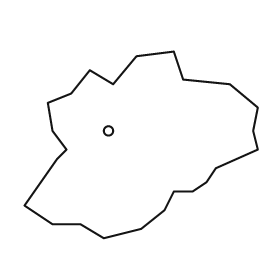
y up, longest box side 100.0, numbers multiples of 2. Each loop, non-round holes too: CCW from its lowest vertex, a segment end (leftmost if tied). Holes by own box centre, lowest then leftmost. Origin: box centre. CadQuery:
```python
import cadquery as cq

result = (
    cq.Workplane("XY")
    .moveTo(-16.0, -40.0)
    .lineTo(0.0, -36.0)
    .lineTo(10.0, -28.0)
    .lineTo(14.0, -20.0)
    .lineTo(22.0, -20.0)
    .lineTo(28.0, -16.0)
    .lineTo(32.0, -10.0)
    .lineTo(50.0, -2.0)
    .lineTo(48.0, 6.0)
    .lineTo(50.0, 16.0)
    .lineTo(38.0, 26.0)
    .lineTo(18.0, 28.0)
    .lineTo(14.0, 40.0)
    .lineTo(-2.0, 38.0)
    .lineTo(-12.0, 26.0)
    .lineTo(-22.0, 32.0)
    .lineTo(-30.0, 22.0)
    .lineTo(-40.0, 18.0)
    .lineTo(-38.0, 6.0)
    .lineTo(-32.0, -2.0)
    .lineTo(-36.0, -6.0)
    .lineTo(-50.0, -26.0)
    .lineTo(-38.0, -34.0)
    .lineTo(-26.0, -34.0)
    .close()
    .moveTo(-14.0, 6.0)
    .circle(2.0)
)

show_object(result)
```